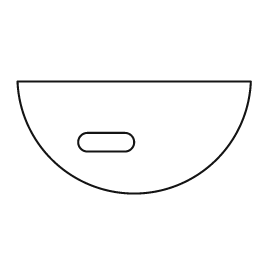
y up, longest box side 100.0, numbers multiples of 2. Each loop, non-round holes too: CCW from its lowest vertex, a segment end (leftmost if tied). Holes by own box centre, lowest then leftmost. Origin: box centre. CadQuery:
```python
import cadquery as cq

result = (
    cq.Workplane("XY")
    .moveTo(-50.0, 24.0)
    .threePointArc((0.0, -24.0), (50.0, 24.0))
    .close()
    .moveTo(-20.0, -6.0)
    .lineTo(-4.0, -6.0)
    .threePointArc((0.0, -2.0), (-4.0, 2.0))
    .lineTo(-20.0, 2.0)
    .threePointArc((-24.0, -2.0), (-20.0, -6.0))
    .close()
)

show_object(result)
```